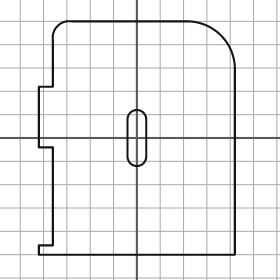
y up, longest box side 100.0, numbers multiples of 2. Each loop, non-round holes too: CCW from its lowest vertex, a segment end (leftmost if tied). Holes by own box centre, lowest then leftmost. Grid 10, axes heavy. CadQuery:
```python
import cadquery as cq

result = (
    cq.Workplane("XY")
    .moveTo(-42.0, -50.0)
    .lineTo(42.0, -50.0)
    .lineTo(42.0, 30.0)
    .threePointArc((36.0, 44.0), (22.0, 50.0))
    .lineTo(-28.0, 50.0)
    .threePointArc((-34.0, 48.0), (-36.0, 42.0))
    .lineTo(-36.0, 22.0)
    .lineTo(-42.0, 22.0)
    .lineTo(-42.0, -4.0)
    .lineTo(-36.0, -4.0)
    .lineTo(-36.0, -46.0)
    .lineTo(-42.0, -46.0)
    .close()
    .moveTo(-4.0, -8.0)
    .threePointArc((0.0, -12.0), (4.0, -8.0))
    .lineTo(4.0, 8.0)
    .threePointArc((0.0, 12.0), (-4.0, 8.0))
    .close()
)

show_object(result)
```